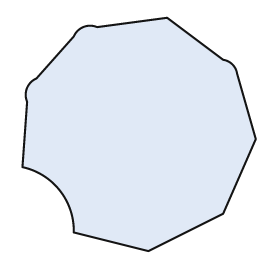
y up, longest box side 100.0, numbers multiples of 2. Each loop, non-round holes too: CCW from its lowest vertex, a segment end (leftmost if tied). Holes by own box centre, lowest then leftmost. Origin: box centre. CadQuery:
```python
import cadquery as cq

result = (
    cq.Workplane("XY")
    .moveTo(4.0, -50.0)
    .lineTo(36.0, -34.0)
    .lineTo(50.0, -2.0)
    .lineTo(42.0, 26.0)
    .threePointArc((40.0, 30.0), (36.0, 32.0))
    .lineTo(12.0, 50.0)
    .lineTo(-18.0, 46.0)
    .threePointArc((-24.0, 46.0), (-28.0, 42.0))
    .lineTo(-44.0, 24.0)
    .threePointArc((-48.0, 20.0), (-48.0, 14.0))
    .lineTo(-50.0, -14.0)
    .threePointArc((-34.0, -24.0), (-28.0, -42.0))
    .close()
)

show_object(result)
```